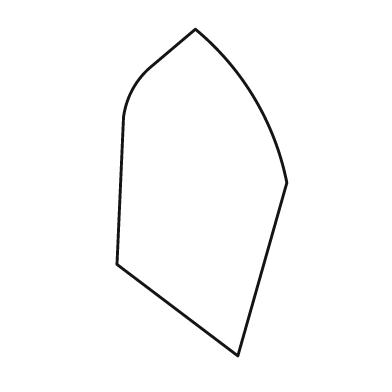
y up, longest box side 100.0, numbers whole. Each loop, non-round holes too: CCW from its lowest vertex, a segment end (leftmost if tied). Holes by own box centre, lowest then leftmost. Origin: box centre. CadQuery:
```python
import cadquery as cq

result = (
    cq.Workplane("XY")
    .moveTo(11.0, -50.0)
    .lineTo(26.0, 3.0)
    .threePointArc((16.0, 29.0), (-2.0, 50.0))
    .lineTo(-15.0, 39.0)
    .threePointArc((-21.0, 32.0), (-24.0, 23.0))
    .lineTo(-26.0, -22.0)
    .close()
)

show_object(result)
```